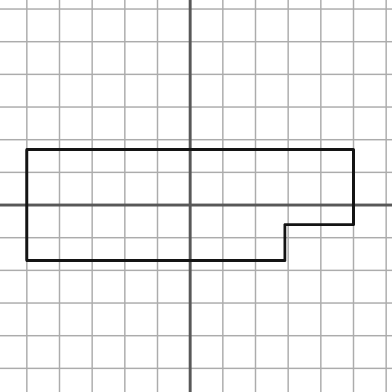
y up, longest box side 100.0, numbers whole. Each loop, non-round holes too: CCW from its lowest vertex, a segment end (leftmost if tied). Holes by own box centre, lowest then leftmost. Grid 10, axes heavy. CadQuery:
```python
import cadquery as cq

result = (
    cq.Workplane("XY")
    .moveTo(-50.0, -17.0)
    .lineTo(29.0, -17.0)
    .lineTo(29.0, -6.0)
    .lineTo(50.0, -6.0)
    .lineTo(50.0, 17.0)
    .lineTo(-50.0, 17.0)
    .close()
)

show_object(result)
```